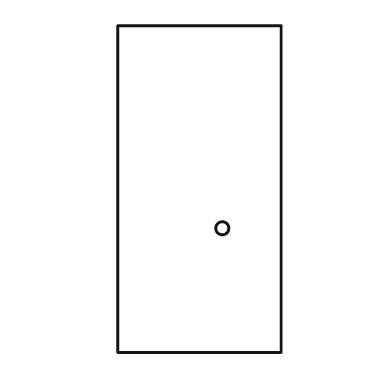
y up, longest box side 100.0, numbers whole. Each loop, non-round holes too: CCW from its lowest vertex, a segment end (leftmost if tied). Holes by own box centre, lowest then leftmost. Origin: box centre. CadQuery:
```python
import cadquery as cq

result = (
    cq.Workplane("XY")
    .moveTo(-25.0, -50.0)
    .lineTo(25.0, -50.0)
    .lineTo(25.0, 50.0)
    .lineTo(-25.0, 50.0)
    .close()
    .moveTo(7.0, -12.0)
    .circle(2.0)
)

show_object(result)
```